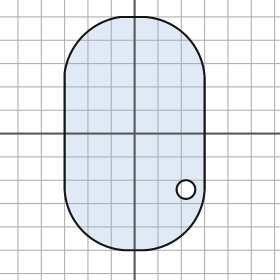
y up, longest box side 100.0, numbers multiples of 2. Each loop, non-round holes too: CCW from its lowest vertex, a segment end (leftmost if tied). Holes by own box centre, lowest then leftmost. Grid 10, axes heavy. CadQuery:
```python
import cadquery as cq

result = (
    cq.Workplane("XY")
    .moveTo(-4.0, -50.0)
    .lineTo(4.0, -50.0)
    .threePointArc((22.0, -42.0), (30.0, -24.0))
    .lineTo(30.0, 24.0)
    .threePointArc((22.0, 42.0), (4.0, 50.0))
    .lineTo(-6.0, 50.0)
    .threePointArc((-22.0, 42.0), (-30.0, 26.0))
    .lineTo(-30.0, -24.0)
    .threePointArc((-22.0, -42.0), (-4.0, -50.0))
    .close()
    .moveTo(22.0, -24.0)
    .circle(4.0)
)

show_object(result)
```